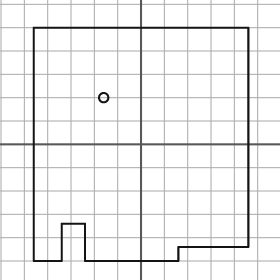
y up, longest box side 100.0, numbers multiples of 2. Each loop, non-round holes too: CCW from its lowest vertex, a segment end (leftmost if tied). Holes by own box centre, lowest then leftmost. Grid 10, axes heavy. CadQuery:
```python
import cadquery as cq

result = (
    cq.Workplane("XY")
    .moveTo(-46.0, -50.0)
    .lineTo(-34.0, -50.0)
    .lineTo(-34.0, -34.0)
    .lineTo(-24.0, -34.0)
    .lineTo(-24.0, -50.0)
    .lineTo(16.0, -50.0)
    .lineTo(16.0, -44.0)
    .lineTo(46.0, -44.0)
    .lineTo(46.0, 50.0)
    .lineTo(-46.0, 50.0)
    .close()
    .moveTo(-16.0, 20.0)
    .circle(2.0)
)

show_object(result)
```